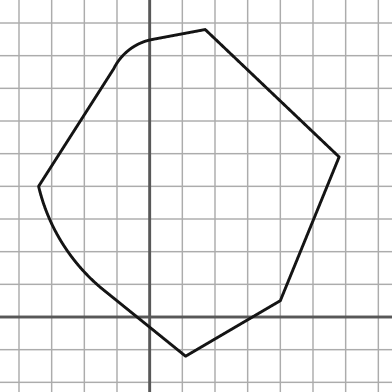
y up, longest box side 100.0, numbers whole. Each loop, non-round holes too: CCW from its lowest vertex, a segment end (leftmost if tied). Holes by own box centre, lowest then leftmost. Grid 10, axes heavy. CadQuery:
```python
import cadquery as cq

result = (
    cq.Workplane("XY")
    .moveTo(11.0, -12.0)
    .lineTo(40.0, 5.0)
    .lineTo(58.0, 49.0)
    .lineTo(17.0, 88.0)
    .lineTo(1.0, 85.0)
    .threePointArc((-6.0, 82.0), (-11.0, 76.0))
    .lineTo(-34.0, 40.0)
    .threePointArc((-27.0, 23.0), (-15.0, 9.0))
    .close()
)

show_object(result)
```